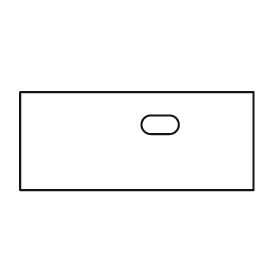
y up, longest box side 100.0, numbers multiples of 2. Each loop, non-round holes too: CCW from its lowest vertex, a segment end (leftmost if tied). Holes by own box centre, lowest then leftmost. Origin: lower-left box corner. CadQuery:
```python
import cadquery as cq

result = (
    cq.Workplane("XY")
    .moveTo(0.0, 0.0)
    .lineTo(100.0, 0.0)
    .lineTo(100.0, 42.0)
    .lineTo(0.0, 42.0)
    .close()
    .moveTo(56.0, 24.0)
    .lineTo(64.0, 24.0)
    .threePointArc((68.0, 28.0), (64.0, 32.0))
    .lineTo(56.0, 32.0)
    .threePointArc((52.0, 28.0), (56.0, 24.0))
    .close()
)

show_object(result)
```